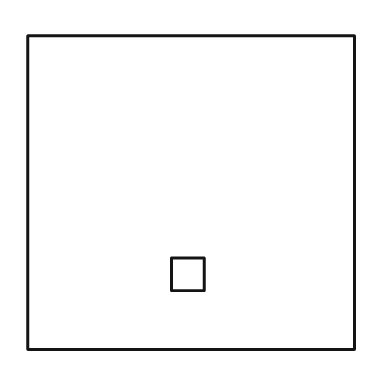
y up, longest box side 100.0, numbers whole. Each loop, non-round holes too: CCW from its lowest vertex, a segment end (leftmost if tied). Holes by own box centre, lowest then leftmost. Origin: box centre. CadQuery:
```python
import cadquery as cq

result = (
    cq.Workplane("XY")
    .moveTo(-50.0, -48.0)
    .lineTo(50.0, -48.0)
    .lineTo(50.0, 48.0)
    .lineTo(-50.0, 48.0)
    .close()
    .moveTo(-6.0, -30.0)
    .lineTo(4.0, -30.0)
    .lineTo(4.0, -20.0)
    .lineTo(-6.0, -20.0)
    .close()
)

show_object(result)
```